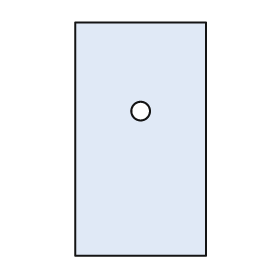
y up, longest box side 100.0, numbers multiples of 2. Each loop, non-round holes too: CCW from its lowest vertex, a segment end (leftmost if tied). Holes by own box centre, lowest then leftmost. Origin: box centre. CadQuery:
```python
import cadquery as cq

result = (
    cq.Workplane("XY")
    .moveTo(-28.0, -50.0)
    .lineTo(28.0, -50.0)
    .lineTo(28.0, 50.0)
    .lineTo(-28.0, 50.0)
    .close()
    .moveTo(0.0, 12.0)
    .circle(4.0)
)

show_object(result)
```